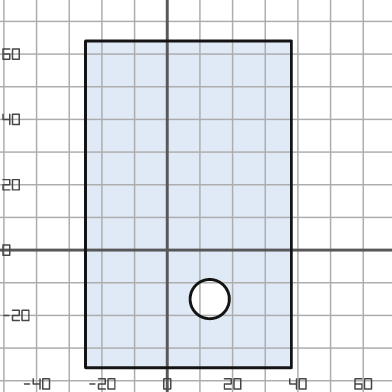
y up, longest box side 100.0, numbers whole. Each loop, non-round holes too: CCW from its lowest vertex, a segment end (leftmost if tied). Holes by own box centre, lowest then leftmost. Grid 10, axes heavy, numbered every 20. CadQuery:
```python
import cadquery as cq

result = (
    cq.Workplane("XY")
    .moveTo(-25.0, -36.0)
    .lineTo(38.0, -36.0)
    .lineTo(38.0, 64.0)
    .lineTo(-25.0, 64.0)
    .close()
    .moveTo(13.0, -15.0)
    .circle(6.0)
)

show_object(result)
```